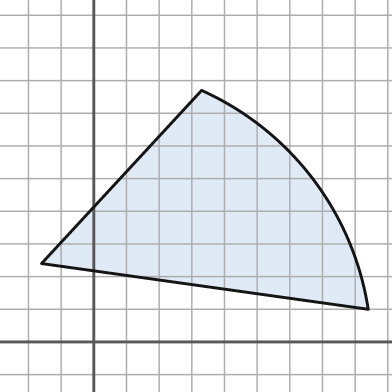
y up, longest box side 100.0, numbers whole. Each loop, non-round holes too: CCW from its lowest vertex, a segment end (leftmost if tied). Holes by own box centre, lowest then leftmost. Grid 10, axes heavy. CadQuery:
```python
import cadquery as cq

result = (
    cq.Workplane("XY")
    .moveTo(84.0, 10.0)
    .threePointArc((67.0, 50.0), (33.0, 77.0))
    .lineTo(-16.0, 24.0)
    .close()
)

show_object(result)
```